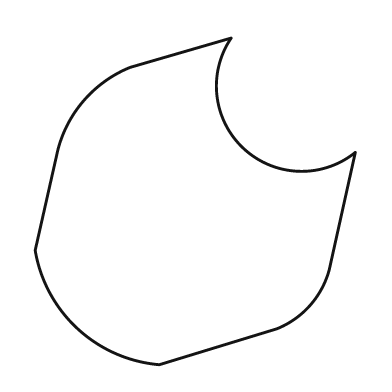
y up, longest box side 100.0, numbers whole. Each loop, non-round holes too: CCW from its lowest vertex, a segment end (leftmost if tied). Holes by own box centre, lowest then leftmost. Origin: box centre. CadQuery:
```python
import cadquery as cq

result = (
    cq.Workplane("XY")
    .moveTo(-11.0, -50.0)
    .lineTo(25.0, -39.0)
    .threePointArc((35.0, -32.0), (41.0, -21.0))
    .lineTo(49.0, 15.0)
    .threePointArc((15.0, 16.0), (11.0, 50.0))
    .lineTo(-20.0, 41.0)
    .threePointArc((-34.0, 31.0), (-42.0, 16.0))
    .lineTo(-49.0, -15.0)
    .threePointArc((-36.0, -39.0), (-11.0, -50.0))
    .close()
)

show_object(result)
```